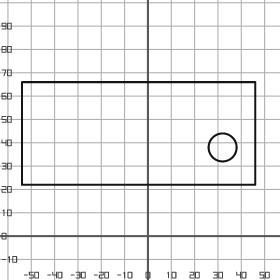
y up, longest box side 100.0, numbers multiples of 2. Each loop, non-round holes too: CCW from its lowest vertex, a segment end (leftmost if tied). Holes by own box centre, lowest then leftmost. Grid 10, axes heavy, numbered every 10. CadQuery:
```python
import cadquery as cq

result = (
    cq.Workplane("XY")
    .moveTo(-54.0, 22.0)
    .lineTo(46.0, 22.0)
    .lineTo(46.0, 66.0)
    .lineTo(-54.0, 66.0)
    .close()
    .moveTo(32.0, 38.0)
    .circle(6.0)
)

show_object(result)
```